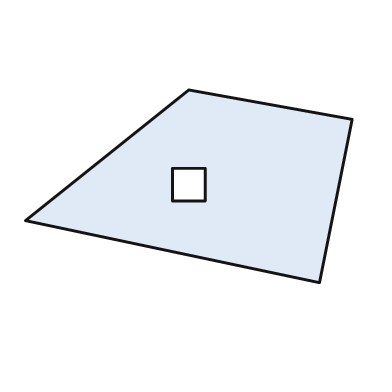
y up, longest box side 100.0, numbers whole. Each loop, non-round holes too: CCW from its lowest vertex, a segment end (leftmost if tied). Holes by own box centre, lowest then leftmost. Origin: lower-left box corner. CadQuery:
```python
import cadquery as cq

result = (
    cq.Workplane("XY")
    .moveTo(90.0, 0.0)
    .lineTo(100.0, 50.0)
    .lineTo(50.0, 59.0)
    .lineTo(0.0, 19.0)
    .close()
    .moveTo(45.0, 25.0)
    .lineTo(55.0, 25.0)
    .lineTo(55.0, 35.0)
    .lineTo(45.0, 35.0)
    .close()
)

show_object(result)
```